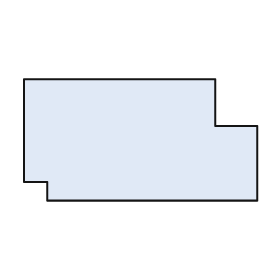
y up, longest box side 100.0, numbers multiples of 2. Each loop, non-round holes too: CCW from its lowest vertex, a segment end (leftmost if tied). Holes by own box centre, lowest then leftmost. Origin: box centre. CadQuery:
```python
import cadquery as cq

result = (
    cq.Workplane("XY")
    .moveTo(-40.0, -26.0)
    .lineTo(50.0, -26.0)
    .lineTo(50.0, 6.0)
    .lineTo(32.0, 6.0)
    .lineTo(32.0, 26.0)
    .lineTo(-50.0, 26.0)
    .lineTo(-50.0, -18.0)
    .lineTo(-40.0, -18.0)
    .close()
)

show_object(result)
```